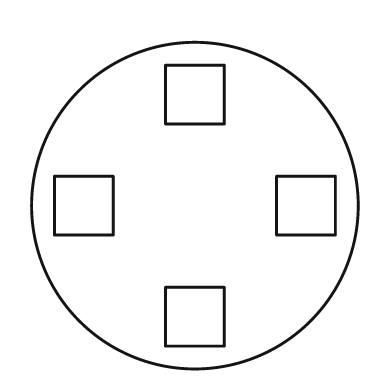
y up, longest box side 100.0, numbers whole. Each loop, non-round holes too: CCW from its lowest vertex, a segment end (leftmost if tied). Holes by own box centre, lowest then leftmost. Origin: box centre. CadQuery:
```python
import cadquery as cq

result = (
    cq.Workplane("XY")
    .moveTo(0.0, 0.0)
    .circle(50.0)
    .moveTo(-9.0, -43.0)
    .lineTo(9.0, -43.0)
    .lineTo(9.0, -25.0)
    .lineTo(-9.0, -25.0)
    .close()
    .moveTo(-43.0, -9.0)
    .lineTo(-25.0, -9.0)
    .lineTo(-25.0, 9.0)
    .lineTo(-43.0, 9.0)
    .close()
    .moveTo(25.0, -9.0)
    .lineTo(43.0, -9.0)
    .lineTo(43.0, 9.0)
    .lineTo(25.0, 9.0)
    .close()
    .moveTo(-9.0, 25.0)
    .lineTo(9.0, 25.0)
    .lineTo(9.0, 43.0)
    .lineTo(-9.0, 43.0)
    .close()
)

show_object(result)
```